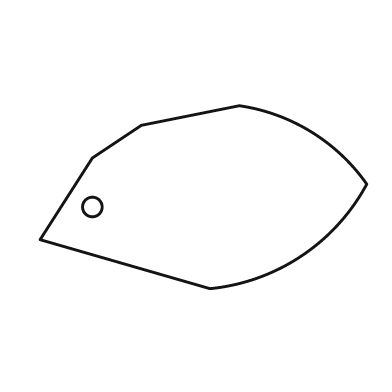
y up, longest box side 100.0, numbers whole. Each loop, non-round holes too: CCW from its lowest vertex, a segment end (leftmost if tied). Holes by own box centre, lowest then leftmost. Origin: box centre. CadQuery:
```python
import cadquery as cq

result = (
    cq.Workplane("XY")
    .moveTo(2.0, -28.0)
    .threePointArc((30.0, -18.0), (50.0, 4.0))
    .threePointArc((33.0, 20.0), (11.0, 28.0))
    .lineTo(-19.0, 22.0)
    .lineTo(-34.0, 12.0)
    .lineTo(-50.0, -13.0)
    .close()
    .moveTo(-34.0, -3.0)
    .circle(3.0)
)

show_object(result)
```